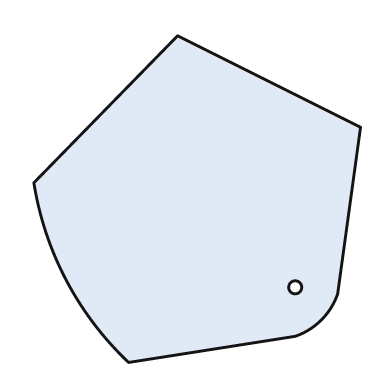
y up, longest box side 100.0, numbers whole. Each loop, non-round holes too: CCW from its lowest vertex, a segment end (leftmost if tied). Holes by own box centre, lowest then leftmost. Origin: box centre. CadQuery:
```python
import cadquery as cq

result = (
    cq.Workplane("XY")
    .moveTo(-21.0, -50.0)
    .lineTo(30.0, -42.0)
    .threePointArc((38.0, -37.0), (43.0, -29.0))
    .lineTo(50.0, 22.0)
    .lineTo(-6.0, 50.0)
    .lineTo(-50.0, 5.0)
    .threePointArc((-40.0, -25.0), (-21.0, -50.0))
    .close()
    .moveTo(30.0, -27.0)
    .circle(2.0)
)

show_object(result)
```